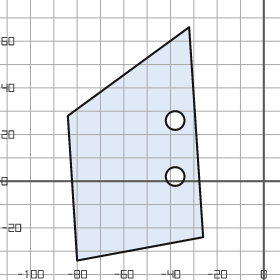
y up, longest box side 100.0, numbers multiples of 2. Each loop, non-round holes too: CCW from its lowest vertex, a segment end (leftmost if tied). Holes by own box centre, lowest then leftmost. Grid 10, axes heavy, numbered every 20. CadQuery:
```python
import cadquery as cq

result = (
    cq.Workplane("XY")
    .moveTo(-80.0, -34.0)
    .lineTo(-26.0, -24.0)
    .lineTo(-32.0, 66.0)
    .lineTo(-84.0, 28.0)
    .close()
    .moveTo(-38.0, 2.0)
    .circle(4.0)
    .moveTo(-38.0, 26.0)
    .circle(4.0)
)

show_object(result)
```